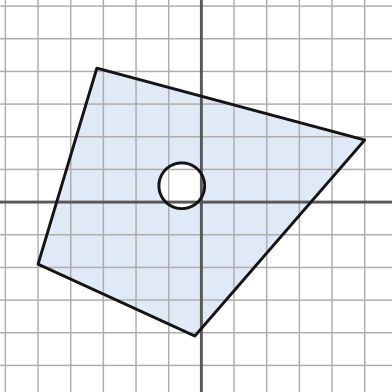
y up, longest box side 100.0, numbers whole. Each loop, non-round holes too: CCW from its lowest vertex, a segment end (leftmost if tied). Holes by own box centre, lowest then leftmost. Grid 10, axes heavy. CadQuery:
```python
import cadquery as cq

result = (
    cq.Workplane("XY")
    .moveTo(-2.0, -41.0)
    .lineTo(50.0, 19.0)
    .lineTo(-32.0, 41.0)
    .lineTo(-50.0, -19.0)
    .close()
    .moveTo(-6.0, 5.0)
    .circle(7.0)
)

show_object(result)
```